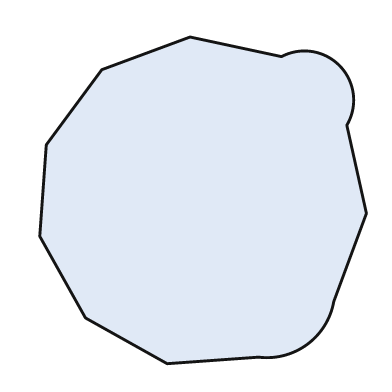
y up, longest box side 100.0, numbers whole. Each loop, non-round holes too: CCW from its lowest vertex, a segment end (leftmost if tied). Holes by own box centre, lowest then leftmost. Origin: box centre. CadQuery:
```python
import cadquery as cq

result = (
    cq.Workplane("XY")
    .moveTo(-11.0, -50.0)
    .lineTo(17.0, -48.0)
    .threePointArc((32.0, -44.0), (40.0, -31.0))
    .lineTo(50.0, -4.0)
    .lineTo(44.0, 23.0)
    .threePointArc((42.0, 41.0), (24.0, 44.0))
    .lineTo(-4.0, 50.0)
    .lineTo(-31.0, 40.0)
    .lineTo(-48.0, 17.0)
    .lineTo(-50.0, -11.0)
    .lineTo(-36.0, -36.0)
    .close()
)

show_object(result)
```